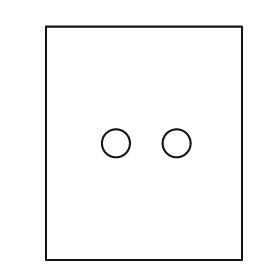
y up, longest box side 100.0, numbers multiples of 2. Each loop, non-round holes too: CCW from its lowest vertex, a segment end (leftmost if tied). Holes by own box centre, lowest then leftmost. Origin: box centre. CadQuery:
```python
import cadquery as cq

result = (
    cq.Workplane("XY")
    .moveTo(-42.0, -50.0)
    .lineTo(42.0, -50.0)
    .lineTo(42.0, 50.0)
    .lineTo(-42.0, 50.0)
    .close()
    .moveTo(-12.0, 0.0)
    .circle(6.0)
    .moveTo(14.0, 0.0)
    .circle(6.0)
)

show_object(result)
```